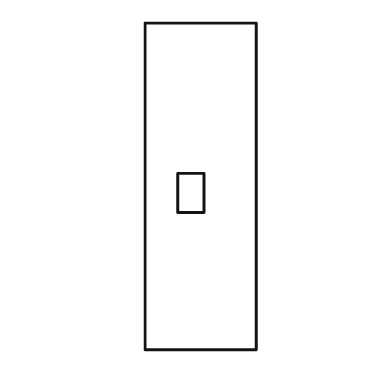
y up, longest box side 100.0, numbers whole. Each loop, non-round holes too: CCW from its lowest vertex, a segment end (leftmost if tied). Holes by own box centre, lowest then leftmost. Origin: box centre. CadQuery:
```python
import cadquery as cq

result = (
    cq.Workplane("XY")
    .moveTo(-17.0, -50.0)
    .lineTo(17.0, -50.0)
    .lineTo(17.0, 50.0)
    .lineTo(-17.0, 50.0)
    .close()
    .moveTo(-7.0, -8.0)
    .lineTo(1.0, -8.0)
    .lineTo(1.0, 4.0)
    .lineTo(-7.0, 4.0)
    .close()
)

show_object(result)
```